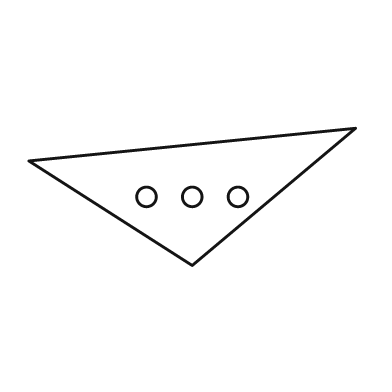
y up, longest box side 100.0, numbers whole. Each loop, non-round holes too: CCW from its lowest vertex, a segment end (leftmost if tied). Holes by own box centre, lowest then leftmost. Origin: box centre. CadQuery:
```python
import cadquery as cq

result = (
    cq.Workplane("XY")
    .moveTo(0.0, -21.0)
    .lineTo(50.0, 21.0)
    .lineTo(-50.0, 11.0)
    .close()
    .moveTo(-14.0, 0.0)
    .circle(3.0)
    .moveTo(0.0, 0.0)
    .circle(3.0)
    .moveTo(14.0, 0.0)
    .circle(3.0)
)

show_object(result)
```